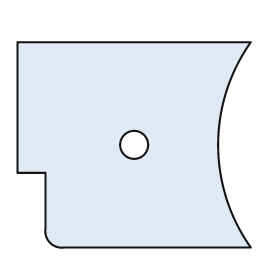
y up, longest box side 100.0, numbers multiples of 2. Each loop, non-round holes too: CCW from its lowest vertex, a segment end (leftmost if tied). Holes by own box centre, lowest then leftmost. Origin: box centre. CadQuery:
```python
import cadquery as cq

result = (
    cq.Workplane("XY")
    .moveTo(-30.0, -44.0)
    .lineTo(50.0, -44.0)
    .threePointArc((36.0, 0.0), (50.0, 44.0))
    .lineTo(-50.0, 44.0)
    .lineTo(-50.0, -12.0)
    .lineTo(-38.0, -12.0)
    .lineTo(-38.0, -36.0)
    .threePointArc((-36.0, -42.0), (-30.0, -44.0))
    .close()
    .moveTo(0.0, 0.0)
    .circle(6.0)
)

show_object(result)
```